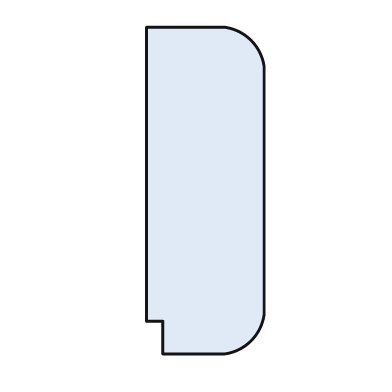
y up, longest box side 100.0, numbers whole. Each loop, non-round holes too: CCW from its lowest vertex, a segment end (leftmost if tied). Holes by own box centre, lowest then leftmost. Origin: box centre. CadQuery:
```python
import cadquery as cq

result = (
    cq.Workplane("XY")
    .moveTo(-13.0, -50.0)
    .lineTo(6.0, -50.0)
    .threePointArc((14.0, -46.0), (18.0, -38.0))
    .lineTo(18.0, 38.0)
    .threePointArc((14.0, 46.0), (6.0, 50.0))
    .lineTo(-18.0, 50.0)
    .lineTo(-18.0, -40.0)
    .lineTo(-13.0, -40.0)
    .close()
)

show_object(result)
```